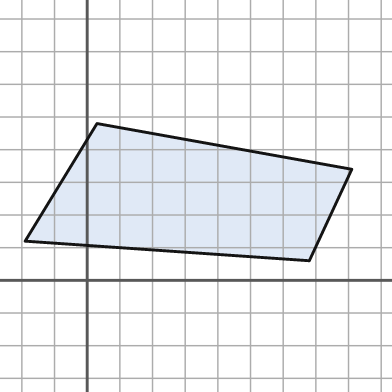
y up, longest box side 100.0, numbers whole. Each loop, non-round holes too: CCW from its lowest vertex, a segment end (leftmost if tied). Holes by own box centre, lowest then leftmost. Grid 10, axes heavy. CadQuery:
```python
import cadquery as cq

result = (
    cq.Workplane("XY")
    .moveTo(68.0, 6.0)
    .lineTo(81.0, 34.0)
    .lineTo(3.0, 48.0)
    .lineTo(-19.0, 12.0)
    .close()
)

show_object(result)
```